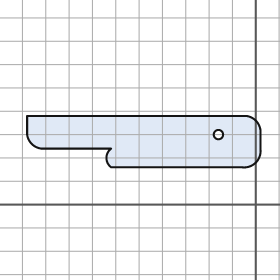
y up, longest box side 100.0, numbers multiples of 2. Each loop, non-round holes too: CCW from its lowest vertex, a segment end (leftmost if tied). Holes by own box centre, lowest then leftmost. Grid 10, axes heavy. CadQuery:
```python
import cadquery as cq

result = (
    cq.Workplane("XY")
    .moveTo(-62.0, 16.0)
    .lineTo(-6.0, 16.0)
    .threePointArc((0.0, 18.0), (2.0, 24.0))
    .lineTo(2.0, 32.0)
    .threePointArc((0.0, 36.0), (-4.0, 38.0))
    .lineTo(-98.0, 38.0)
    .lineTo(-98.0, 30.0)
    .threePointArc((-96.0, 26.0), (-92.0, 24.0))
    .lineTo(-62.0, 24.0)
    .threePointArc((-64.0, 20.0), (-62.0, 16.0))
    .close()
    .moveTo(-16.0, 30.0)
    .circle(2.0)
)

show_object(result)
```